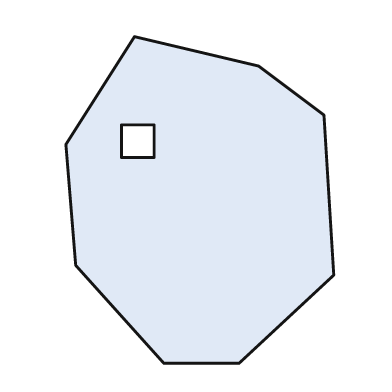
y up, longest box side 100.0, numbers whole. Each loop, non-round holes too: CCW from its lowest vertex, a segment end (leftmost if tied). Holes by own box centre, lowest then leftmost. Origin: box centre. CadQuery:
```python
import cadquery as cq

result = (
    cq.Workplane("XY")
    .moveTo(-11.0, -50.0)
    .lineTo(12.0, -50.0)
    .lineTo(41.0, -23.0)
    .lineTo(38.0, 26.0)
    .lineTo(18.0, 41.0)
    .lineTo(-20.0, 50.0)
    .lineTo(-41.0, 17.0)
    .lineTo(-38.0, -20.0)
    .close()
    .moveTo(-24.0, 13.0)
    .lineTo(-14.0, 13.0)
    .lineTo(-14.0, 23.0)
    .lineTo(-24.0, 23.0)
    .close()
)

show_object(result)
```